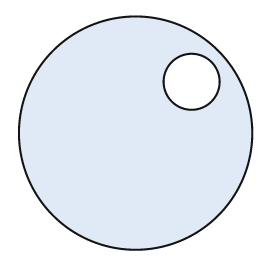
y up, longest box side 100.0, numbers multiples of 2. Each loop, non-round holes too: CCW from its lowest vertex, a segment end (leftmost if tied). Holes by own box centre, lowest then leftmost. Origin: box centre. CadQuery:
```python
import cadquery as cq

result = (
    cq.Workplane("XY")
    .moveTo(0.0, 0.0)
    .circle(50.0)
    .moveTo(24.0, 22.0)
    .circle(12.0)
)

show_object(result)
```